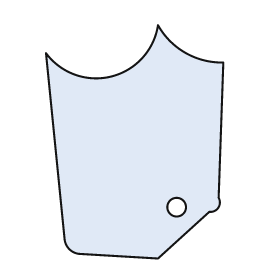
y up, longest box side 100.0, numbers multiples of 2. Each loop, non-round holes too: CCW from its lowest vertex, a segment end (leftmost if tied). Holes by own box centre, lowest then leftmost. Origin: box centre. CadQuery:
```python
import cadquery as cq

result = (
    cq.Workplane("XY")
    .moveTo(10.0, -50.0)
    .lineTo(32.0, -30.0)
    .threePointArc((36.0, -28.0), (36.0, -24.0))
    .lineTo(38.0, 34.0)
    .threePointArc((22.0, 38.0), (10.0, 50.0))
    .threePointArc((-10.0, 28.0), (-38.0, 38.0))
    .lineTo(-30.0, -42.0)
    .threePointArc((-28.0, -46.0), (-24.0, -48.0))
    .close()
    .moveTo(18.0, -28.0)
    .circle(4.0)
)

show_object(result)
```